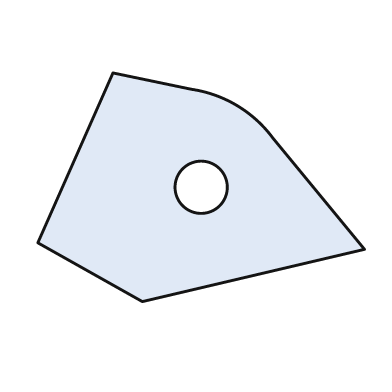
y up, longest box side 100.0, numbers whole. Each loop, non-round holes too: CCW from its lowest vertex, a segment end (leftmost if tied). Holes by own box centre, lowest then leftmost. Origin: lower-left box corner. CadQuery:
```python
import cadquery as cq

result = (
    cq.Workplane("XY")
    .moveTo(32.0, 0.0)
    .lineTo(100.0, 16.0)
    .lineTo(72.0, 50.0)
    .threePointArc((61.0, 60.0), (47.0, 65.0))
    .lineTo(23.0, 70.0)
    .lineTo(0.0, 18.0)
    .close()
    .moveTo(50.0, 35.0)
    .circle(8.0)
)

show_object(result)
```